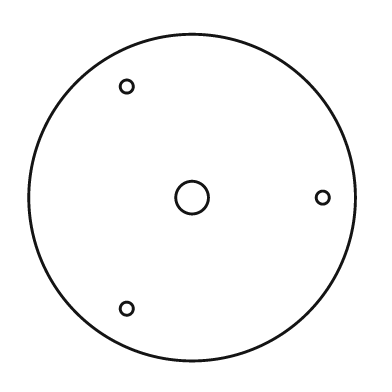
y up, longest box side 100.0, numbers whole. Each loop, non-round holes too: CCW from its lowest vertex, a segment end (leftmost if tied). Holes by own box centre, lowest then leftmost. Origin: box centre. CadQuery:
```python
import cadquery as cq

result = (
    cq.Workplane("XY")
    .moveTo(0.0, 0.0)
    .circle(50.0)
    .moveTo(-20.0, -34.0)
    .circle(2.0)
    .moveTo(0.0, 0.0)
    .circle(5.0)
    .moveTo(40.0, 0.0)
    .circle(2.0)
    .moveTo(-20.0, 34.0)
    .circle(2.0)
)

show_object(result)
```